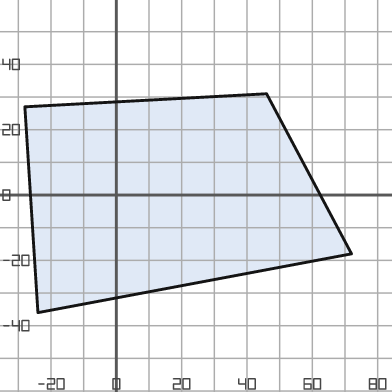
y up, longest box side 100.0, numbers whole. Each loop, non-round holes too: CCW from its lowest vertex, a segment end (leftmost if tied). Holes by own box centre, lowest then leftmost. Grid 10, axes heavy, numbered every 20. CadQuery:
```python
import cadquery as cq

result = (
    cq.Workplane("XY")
    .moveTo(-24.0, -36.0)
    .lineTo(72.0, -18.0)
    .lineTo(46.0, 31.0)
    .lineTo(-28.0, 27.0)
    .close()
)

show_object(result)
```